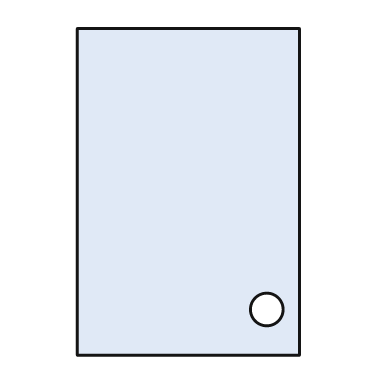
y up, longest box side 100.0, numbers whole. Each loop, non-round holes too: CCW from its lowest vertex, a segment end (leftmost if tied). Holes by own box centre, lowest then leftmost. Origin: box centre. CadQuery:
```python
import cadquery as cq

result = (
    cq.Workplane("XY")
    .moveTo(-34.0, -50.0)
    .lineTo(34.0, -50.0)
    .lineTo(34.0, 50.0)
    .lineTo(-34.0, 50.0)
    .close()
    .moveTo(24.0, -36.0)
    .circle(5.0)
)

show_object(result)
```